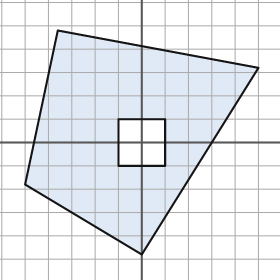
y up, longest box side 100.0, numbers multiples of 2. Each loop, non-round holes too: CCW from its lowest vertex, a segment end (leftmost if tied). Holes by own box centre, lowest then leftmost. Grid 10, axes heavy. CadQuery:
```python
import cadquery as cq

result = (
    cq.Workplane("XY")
    .moveTo(0.0, -48.0)
    .lineTo(50.0, 32.0)
    .lineTo(-36.0, 48.0)
    .lineTo(-50.0, -18.0)
    .close()
    .moveTo(-10.0, -10.0)
    .lineTo(10.0, -10.0)
    .lineTo(10.0, 10.0)
    .lineTo(-10.0, 10.0)
    .close()
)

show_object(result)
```